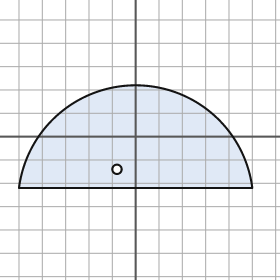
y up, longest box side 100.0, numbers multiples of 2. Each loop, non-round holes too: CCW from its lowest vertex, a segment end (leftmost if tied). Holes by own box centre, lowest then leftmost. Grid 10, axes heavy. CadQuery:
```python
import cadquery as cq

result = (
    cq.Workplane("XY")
    .moveTo(-50.0, -22.0)
    .lineTo(50.0, -22.0)
    .threePointArc((0.0, 22.0), (-50.0, -22.0))
    .close()
    .moveTo(-8.0, -14.0)
    .circle(2.0)
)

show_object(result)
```